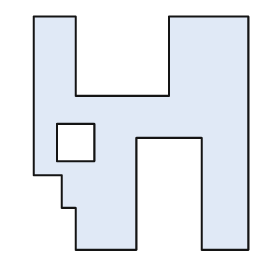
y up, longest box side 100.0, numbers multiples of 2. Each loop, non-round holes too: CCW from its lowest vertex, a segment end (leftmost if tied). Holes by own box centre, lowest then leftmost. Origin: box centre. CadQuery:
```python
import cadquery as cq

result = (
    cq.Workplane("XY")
    .moveTo(-28.0, -50.0)
    .lineTo(-2.0, -50.0)
    .lineTo(-2.0, -2.0)
    .lineTo(26.0, -2.0)
    .lineTo(26.0, -50.0)
    .lineTo(46.0, -50.0)
    .lineTo(46.0, 50.0)
    .lineTo(12.0, 50.0)
    .lineTo(12.0, 16.0)
    .lineTo(-28.0, 16.0)
    .lineTo(-28.0, 50.0)
    .lineTo(-46.0, 50.0)
    .lineTo(-46.0, -18.0)
    .lineTo(-34.0, -18.0)
    .lineTo(-34.0, -32.0)
    .lineTo(-28.0, -32.0)
    .close()
    .moveTo(-36.0, -12.0)
    .lineTo(-20.0, -12.0)
    .lineTo(-20.0, 4.0)
    .lineTo(-36.0, 4.0)
    .close()
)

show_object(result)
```